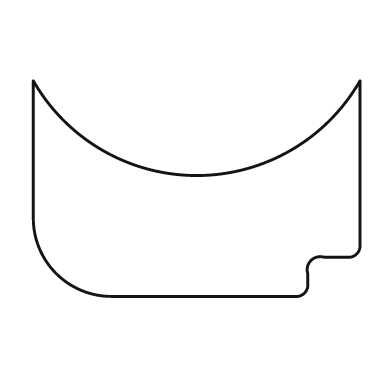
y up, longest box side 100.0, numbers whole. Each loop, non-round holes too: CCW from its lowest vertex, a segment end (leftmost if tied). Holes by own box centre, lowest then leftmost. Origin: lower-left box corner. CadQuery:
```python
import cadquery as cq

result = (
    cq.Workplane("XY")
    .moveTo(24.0, 0.0)
    .lineTo(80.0, 0.0)
    .threePointArc((83.0, 1.0), (84.0, 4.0))
    .lineTo(84.0, 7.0)
    .threePointArc((85.0, 11.0), (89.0, 12.0))
    .lineTo(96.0, 12.0)
    .threePointArc((99.0, 13.0), (100.0, 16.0))
    .lineTo(100.0, 66.0)
    .threePointArc((50.0, 37.0), (0.0, 66.0))
    .lineTo(0.0, 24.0)
    .threePointArc((7.0, 7.0), (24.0, 0.0))
    .close()
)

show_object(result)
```